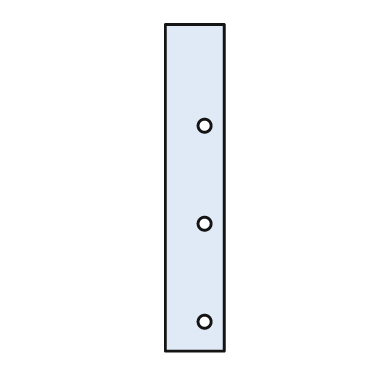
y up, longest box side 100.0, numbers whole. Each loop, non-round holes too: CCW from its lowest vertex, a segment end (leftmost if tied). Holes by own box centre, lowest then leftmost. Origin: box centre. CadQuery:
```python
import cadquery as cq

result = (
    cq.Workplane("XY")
    .moveTo(-9.0, -50.0)
    .lineTo(9.0, -50.0)
    .lineTo(9.0, 50.0)
    .lineTo(-9.0, 50.0)
    .close()
    .moveTo(3.0, -41.0)
    .circle(2.0)
    .moveTo(3.0, -11.0)
    .circle(2.0)
    .moveTo(3.0, 19.0)
    .circle(2.0)
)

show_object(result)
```